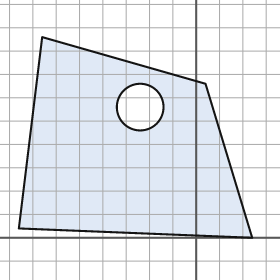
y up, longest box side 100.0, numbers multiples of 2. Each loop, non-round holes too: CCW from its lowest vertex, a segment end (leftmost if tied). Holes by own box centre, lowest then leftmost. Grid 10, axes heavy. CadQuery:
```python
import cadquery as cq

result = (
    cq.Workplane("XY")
    .moveTo(24.0, 0.0)
    .lineTo(4.0, 66.0)
    .lineTo(-66.0, 86.0)
    .lineTo(-76.0, 4.0)
    .close()
    .moveTo(-24.0, 56.0)
    .circle(10.0)
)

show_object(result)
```